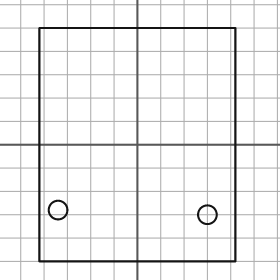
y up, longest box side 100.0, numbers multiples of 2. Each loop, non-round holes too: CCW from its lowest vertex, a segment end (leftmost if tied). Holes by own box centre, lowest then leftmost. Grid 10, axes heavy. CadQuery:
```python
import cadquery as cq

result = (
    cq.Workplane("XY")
    .moveTo(-42.0, -50.0)
    .lineTo(42.0, -50.0)
    .lineTo(42.0, 50.0)
    .lineTo(-42.0, 50.0)
    .close()
    .moveTo(30.0, -30.0)
    .circle(4.0)
    .moveTo(-34.0, -28.0)
    .circle(4.0)
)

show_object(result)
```